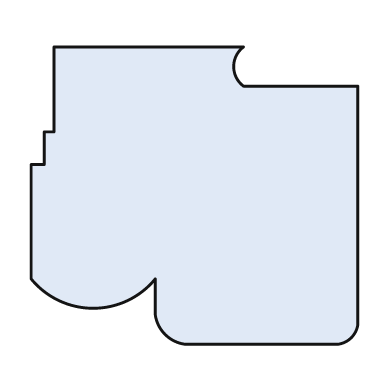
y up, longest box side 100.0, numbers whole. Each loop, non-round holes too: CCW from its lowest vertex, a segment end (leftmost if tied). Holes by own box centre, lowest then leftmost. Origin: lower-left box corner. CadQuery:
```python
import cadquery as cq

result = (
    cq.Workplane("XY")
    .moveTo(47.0, 0.0)
    .lineTo(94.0, 0.0)
    .threePointArc((98.0, 2.0), (100.0, 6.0))
    .lineTo(100.0, 79.0)
    .lineTo(65.0, 79.0)
    .threePointArc((62.0, 85.0), (65.0, 91.0))
    .lineTo(7.0, 91.0)
    .lineTo(7.0, 65.0)
    .lineTo(4.0, 65.0)
    .lineTo(4.0, 55.0)
    .lineTo(0.0, 55.0)
    .lineTo(0.0, 20.0)
    .threePointArc((19.0, 11.0), (38.0, 20.0))
    .lineTo(38.0, 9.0)
    .threePointArc((41.0, 3.0), (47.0, 0.0))
    .close()
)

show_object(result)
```